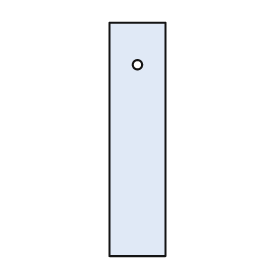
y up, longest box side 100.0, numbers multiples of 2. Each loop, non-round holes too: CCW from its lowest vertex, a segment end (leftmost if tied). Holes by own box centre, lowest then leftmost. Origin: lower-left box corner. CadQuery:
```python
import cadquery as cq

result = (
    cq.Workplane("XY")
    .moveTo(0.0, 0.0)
    .lineTo(24.0, 0.0)
    .lineTo(24.0, 100.0)
    .lineTo(0.0, 100.0)
    .close()
    .moveTo(12.0, 82.0)
    .circle(2.0)
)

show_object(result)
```